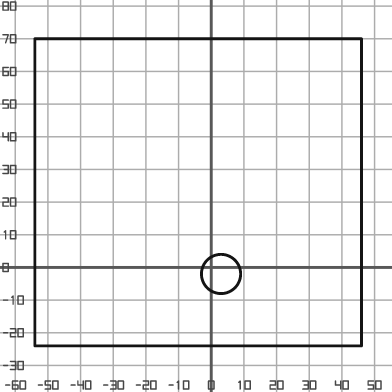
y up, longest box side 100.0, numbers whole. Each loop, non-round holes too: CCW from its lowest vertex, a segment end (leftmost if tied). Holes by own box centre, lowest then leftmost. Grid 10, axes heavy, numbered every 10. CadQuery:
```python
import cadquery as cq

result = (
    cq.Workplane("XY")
    .moveTo(-54.0, -24.0)
    .lineTo(46.0, -24.0)
    .lineTo(46.0, 70.0)
    .lineTo(-54.0, 70.0)
    .close()
    .moveTo(3.0, -2.0)
    .circle(6.0)
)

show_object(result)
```